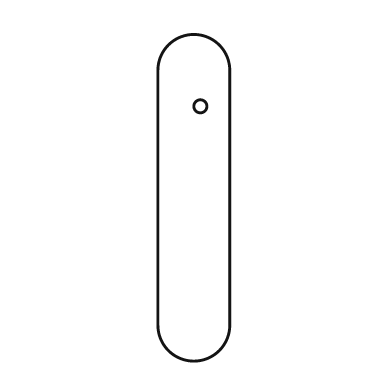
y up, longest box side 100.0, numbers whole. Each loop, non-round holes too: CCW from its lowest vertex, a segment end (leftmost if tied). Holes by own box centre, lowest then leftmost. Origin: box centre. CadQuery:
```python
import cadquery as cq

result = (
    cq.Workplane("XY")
    .moveTo(-11.0, -39.0)
    .threePointArc((0.0, -50.0), (11.0, -39.0))
    .lineTo(11.0, 39.0)
    .threePointArc((0.0, 50.0), (-11.0, 39.0))
    .close()
    .moveTo(2.0, 28.0)
    .circle(2.0)
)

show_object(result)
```